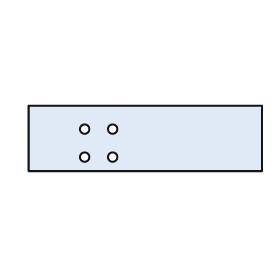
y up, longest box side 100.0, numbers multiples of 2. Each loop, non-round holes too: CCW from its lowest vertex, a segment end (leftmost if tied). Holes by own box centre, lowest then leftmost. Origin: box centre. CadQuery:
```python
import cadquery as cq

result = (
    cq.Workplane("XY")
    .moveTo(-50.0, -14.0)
    .lineTo(50.0, -14.0)
    .lineTo(50.0, 14.0)
    .lineTo(-50.0, 14.0)
    .close()
    .moveTo(-26.0, -8.0)
    .circle(2.0)
    .moveTo(-14.0, -8.0)
    .circle(2.0)
    .moveTo(-26.0, 4.0)
    .circle(2.0)
    .moveTo(-14.0, 4.0)
    .circle(2.0)
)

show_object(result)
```